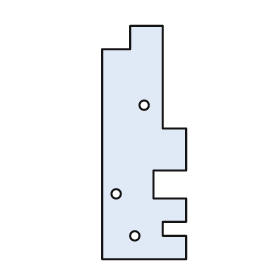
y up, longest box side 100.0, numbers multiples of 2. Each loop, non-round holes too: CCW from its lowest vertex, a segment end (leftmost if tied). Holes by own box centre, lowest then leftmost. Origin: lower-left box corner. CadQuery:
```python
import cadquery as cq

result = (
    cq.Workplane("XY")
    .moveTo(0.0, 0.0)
    .lineTo(36.0, 0.0)
    .lineTo(36.0, 10.0)
    .lineTo(26.0, 10.0)
    .lineTo(26.0, 16.0)
    .lineTo(36.0, 16.0)
    .lineTo(36.0, 26.0)
    .lineTo(22.0, 26.0)
    .lineTo(22.0, 38.0)
    .lineTo(36.0, 38.0)
    .lineTo(36.0, 56.0)
    .lineTo(26.0, 56.0)
    .lineTo(26.0, 100.0)
    .lineTo(12.0, 100.0)
    .lineTo(12.0, 90.0)
    .lineTo(0.0, 90.0)
    .close()
    .moveTo(14.0, 10.0)
    .circle(2.0)
    .moveTo(6.0, 28.0)
    .circle(2.0)
    .moveTo(18.0, 66.0)
    .circle(2.0)
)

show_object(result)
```